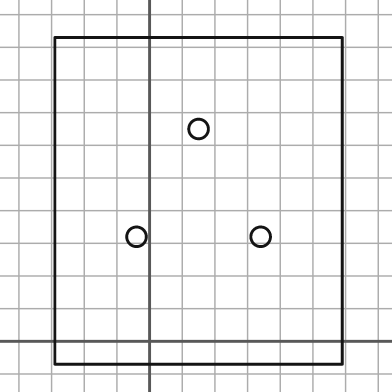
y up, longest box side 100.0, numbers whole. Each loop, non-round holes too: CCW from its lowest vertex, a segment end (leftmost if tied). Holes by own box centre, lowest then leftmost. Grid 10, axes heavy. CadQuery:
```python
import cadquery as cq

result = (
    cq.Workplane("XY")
    .moveTo(-29.0, -7.0)
    .lineTo(59.0, -7.0)
    .lineTo(59.0, 93.0)
    .lineTo(-29.0, 93.0)
    .close()
    .moveTo(-4.0, 32.0)
    .circle(3.0)
    .moveTo(34.0, 32.0)
    .circle(3.0)
    .moveTo(15.0, 65.0)
    .circle(3.0)
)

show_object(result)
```